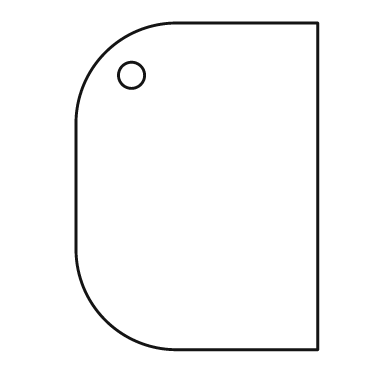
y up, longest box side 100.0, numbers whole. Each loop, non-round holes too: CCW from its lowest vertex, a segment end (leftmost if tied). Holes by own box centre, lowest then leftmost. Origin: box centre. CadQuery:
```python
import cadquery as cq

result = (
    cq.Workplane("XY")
    .moveTo(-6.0, -50.0)
    .lineTo(37.0, -50.0)
    .lineTo(37.0, 50.0)
    .lineTo(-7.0, 50.0)
    .threePointArc((-28.0, 41.0), (-37.0, 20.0))
    .lineTo(-37.0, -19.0)
    .threePointArc((-28.0, -41.0), (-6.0, -50.0))
    .close()
    .moveTo(-20.0, 34.0)
    .circle(4.0)
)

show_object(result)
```